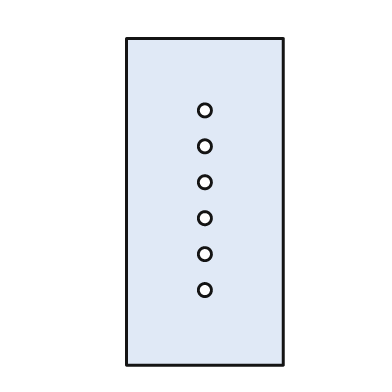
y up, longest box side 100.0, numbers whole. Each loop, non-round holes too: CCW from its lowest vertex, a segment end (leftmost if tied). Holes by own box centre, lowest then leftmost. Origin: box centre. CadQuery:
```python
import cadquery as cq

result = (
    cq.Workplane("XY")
    .moveTo(-24.0, -50.0)
    .lineTo(24.0, -50.0)
    .lineTo(24.0, 50.0)
    .lineTo(-24.0, 50.0)
    .close()
    .moveTo(0.0, -27.0)
    .circle(2.0)
    .moveTo(0.0, -16.0)
    .circle(2.0)
    .moveTo(0.0, -5.0)
    .circle(2.0)
    .moveTo(0.0, 6.0)
    .circle(2.0)
    .moveTo(0.0, 17.0)
    .circle(2.0)
    .moveTo(0.0, 28.0)
    .circle(2.0)
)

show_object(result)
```